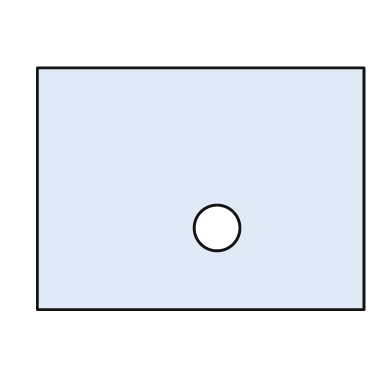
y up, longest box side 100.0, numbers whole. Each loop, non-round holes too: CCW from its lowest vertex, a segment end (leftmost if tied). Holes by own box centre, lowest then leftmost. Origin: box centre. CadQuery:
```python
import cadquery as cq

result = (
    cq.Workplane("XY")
    .moveTo(-50.0, -37.0)
    .lineTo(50.0, -37.0)
    .lineTo(50.0, 37.0)
    .lineTo(-50.0, 37.0)
    .close()
    .moveTo(5.0, -12.0)
    .circle(7.0)
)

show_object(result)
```